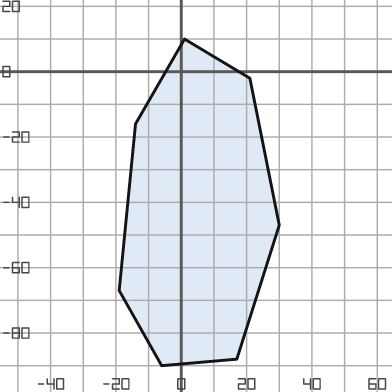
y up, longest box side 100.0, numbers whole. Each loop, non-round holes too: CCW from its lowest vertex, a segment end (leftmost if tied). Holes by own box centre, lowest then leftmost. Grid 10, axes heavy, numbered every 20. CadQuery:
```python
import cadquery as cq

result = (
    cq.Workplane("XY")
    .moveTo(-6.0, -90.0)
    .lineTo(17.0, -88.0)
    .lineTo(30.0, -47.0)
    .lineTo(21.0, -2.0)
    .lineTo(1.0, 10.0)
    .lineTo(-14.0, -16.0)
    .lineTo(-19.0, -67.0)
    .close()
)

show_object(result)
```